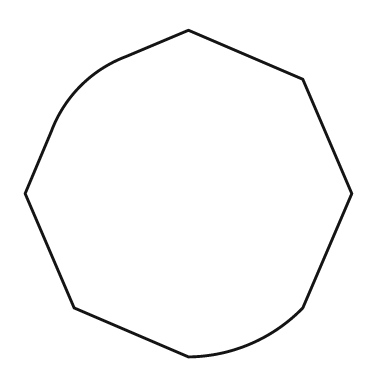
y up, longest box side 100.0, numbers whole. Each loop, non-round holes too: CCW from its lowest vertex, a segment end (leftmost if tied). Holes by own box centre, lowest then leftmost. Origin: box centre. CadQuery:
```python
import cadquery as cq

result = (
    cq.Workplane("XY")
    .moveTo(0.0, -50.0)
    .threePointArc((19.0, -46.0), (35.0, -35.0))
    .lineTo(50.0, 0.0)
    .lineTo(35.0, 35.0)
    .lineTo(0.0, 50.0)
    .lineTo(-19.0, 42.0)
    .threePointArc((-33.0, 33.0), (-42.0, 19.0))
    .lineTo(-50.0, 0.0)
    .lineTo(-35.0, -35.0)
    .close()
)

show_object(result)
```